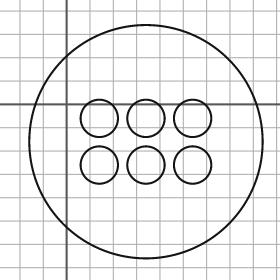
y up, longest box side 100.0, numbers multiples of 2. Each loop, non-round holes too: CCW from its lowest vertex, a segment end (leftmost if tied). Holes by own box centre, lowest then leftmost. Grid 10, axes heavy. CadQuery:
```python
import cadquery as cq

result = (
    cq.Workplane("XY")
    .moveTo(34.0, -16.0)
    .circle(50.0)
    .moveTo(14.0, -26.0)
    .circle(8.0)
    .moveTo(34.0, -26.0)
    .circle(8.0)
    .moveTo(54.0, -26.0)
    .circle(8.0)
    .moveTo(14.0, -6.0)
    .circle(8.0)
    .moveTo(34.0, -6.0)
    .circle(8.0)
    .moveTo(54.0, -6.0)
    .circle(8.0)
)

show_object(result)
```